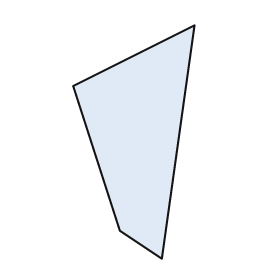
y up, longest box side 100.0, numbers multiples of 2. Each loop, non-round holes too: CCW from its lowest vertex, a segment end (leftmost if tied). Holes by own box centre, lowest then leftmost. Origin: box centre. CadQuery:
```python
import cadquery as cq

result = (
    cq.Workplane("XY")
    .moveTo(12.0, -50.0)
    .lineTo(26.0, 50.0)
    .lineTo(-26.0, 24.0)
    .lineTo(-6.0, -38.0)
    .close()
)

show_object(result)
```